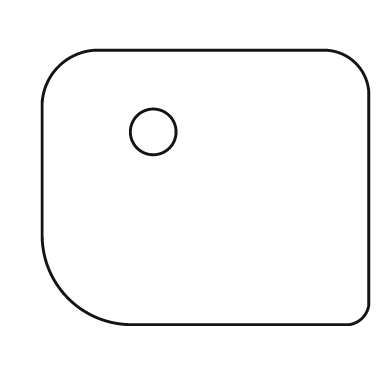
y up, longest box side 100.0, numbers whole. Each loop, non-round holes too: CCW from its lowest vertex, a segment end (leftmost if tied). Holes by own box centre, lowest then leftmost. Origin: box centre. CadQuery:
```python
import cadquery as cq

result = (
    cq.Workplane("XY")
    .moveTo(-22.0, -42.0)
    .lineTo(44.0, -42.0)
    .threePointArc((48.0, -40.0), (50.0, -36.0))
    .lineTo(50.0, 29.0)
    .threePointArc((46.0, 38.0), (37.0, 42.0))
    .lineTo(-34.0, 42.0)
    .threePointArc((-45.0, 37.0), (-50.0, 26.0))
    .lineTo(-50.0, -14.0)
    .threePointArc((-42.0, -34.0), (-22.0, -42.0))
    .close()
    .moveTo(-16.0, 17.0)
    .circle(7.0)
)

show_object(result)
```